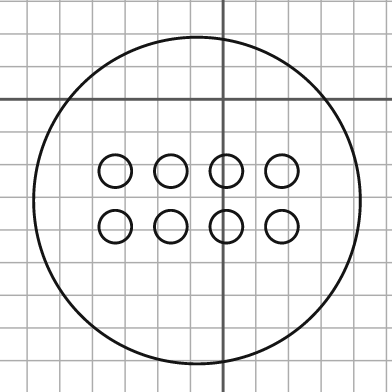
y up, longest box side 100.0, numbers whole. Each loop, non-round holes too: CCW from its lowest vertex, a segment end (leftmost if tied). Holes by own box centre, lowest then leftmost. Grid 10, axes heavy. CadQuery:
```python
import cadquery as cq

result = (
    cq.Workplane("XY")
    .moveTo(-8.0, -31.0)
    .circle(50.0)
    .moveTo(-33.0, -39.0)
    .circle(5.0)
    .moveTo(-16.0, -39.0)
    .circle(5.0)
    .moveTo(1.0, -39.0)
    .circle(5.0)
    .moveTo(18.0, -39.0)
    .circle(5.0)
    .moveTo(-33.0, -22.0)
    .circle(5.0)
    .moveTo(-16.0, -22.0)
    .circle(5.0)
    .moveTo(1.0, -22.0)
    .circle(5.0)
    .moveTo(18.0, -22.0)
    .circle(5.0)
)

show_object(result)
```